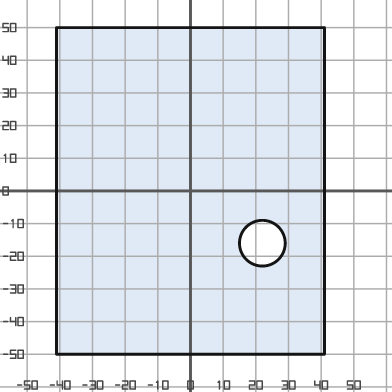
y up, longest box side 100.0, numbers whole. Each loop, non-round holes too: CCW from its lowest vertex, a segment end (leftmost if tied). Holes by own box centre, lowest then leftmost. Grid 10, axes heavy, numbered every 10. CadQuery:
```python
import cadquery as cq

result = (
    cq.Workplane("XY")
    .moveTo(-41.0, -50.0)
    .lineTo(41.0, -50.0)
    .lineTo(41.0, 50.0)
    .lineTo(-41.0, 50.0)
    .close()
    .moveTo(22.0, -16.0)
    .circle(7.0)
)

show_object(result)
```